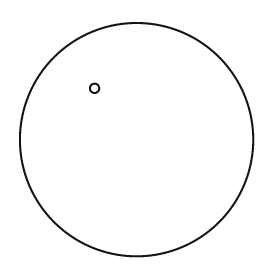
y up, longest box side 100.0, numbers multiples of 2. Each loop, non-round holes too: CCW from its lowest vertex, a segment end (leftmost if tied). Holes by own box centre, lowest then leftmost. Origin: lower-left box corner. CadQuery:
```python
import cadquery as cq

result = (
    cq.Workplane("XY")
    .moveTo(50.0, 50.0)
    .circle(50.0)
    .moveTo(32.0, 72.0)
    .circle(2.0)
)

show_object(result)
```